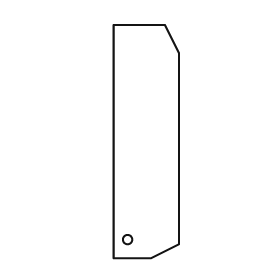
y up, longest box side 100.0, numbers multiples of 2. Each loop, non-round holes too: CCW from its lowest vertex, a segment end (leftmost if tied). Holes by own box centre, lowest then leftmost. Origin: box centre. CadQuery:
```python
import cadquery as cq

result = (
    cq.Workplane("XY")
    .moveTo(-14.0, -50.0)
    .lineTo(2.0, -50.0)
    .lineTo(14.0, -44.0)
    .lineTo(14.0, 38.0)
    .lineTo(8.0, 50.0)
    .lineTo(-14.0, 50.0)
    .close()
    .moveTo(-8.0, -42.0)
    .circle(2.0)
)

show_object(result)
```